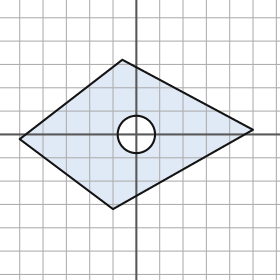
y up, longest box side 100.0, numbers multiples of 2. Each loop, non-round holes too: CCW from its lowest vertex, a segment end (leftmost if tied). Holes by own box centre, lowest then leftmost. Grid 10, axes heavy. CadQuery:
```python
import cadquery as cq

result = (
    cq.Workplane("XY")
    .moveTo(-10.0, -32.0)
    .lineTo(50.0, 2.0)
    .lineTo(-6.0, 32.0)
    .lineTo(-50.0, -2.0)
    .close()
    .moveTo(0.0, 0.0)
    .circle(8.0)
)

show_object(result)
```